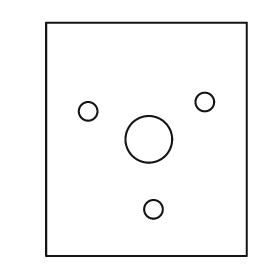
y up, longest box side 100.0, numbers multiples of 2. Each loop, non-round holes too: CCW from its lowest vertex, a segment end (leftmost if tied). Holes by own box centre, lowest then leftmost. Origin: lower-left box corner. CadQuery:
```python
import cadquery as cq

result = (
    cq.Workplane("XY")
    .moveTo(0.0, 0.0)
    .lineTo(86.0, 0.0)
    .lineTo(86.0, 100.0)
    .lineTo(0.0, 100.0)
    .close()
    .moveTo(46.0, 20.0)
    .circle(4.0)
    .moveTo(44.0, 50.0)
    .circle(10.0)
    .moveTo(18.0, 62.0)
    .circle(4.0)
    .moveTo(68.0, 66.0)
    .circle(4.0)
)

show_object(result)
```